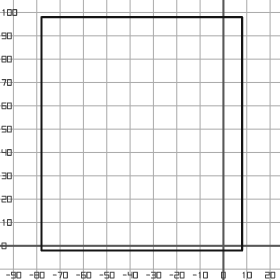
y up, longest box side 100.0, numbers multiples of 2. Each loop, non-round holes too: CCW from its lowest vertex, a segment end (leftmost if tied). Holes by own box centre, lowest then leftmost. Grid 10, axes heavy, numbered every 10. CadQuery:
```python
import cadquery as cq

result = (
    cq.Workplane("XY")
    .moveTo(-78.0, -2.0)
    .lineTo(8.0, -2.0)
    .lineTo(8.0, 98.0)
    .lineTo(-78.0, 98.0)
    .close()
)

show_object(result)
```